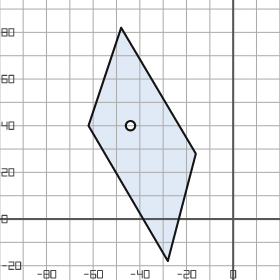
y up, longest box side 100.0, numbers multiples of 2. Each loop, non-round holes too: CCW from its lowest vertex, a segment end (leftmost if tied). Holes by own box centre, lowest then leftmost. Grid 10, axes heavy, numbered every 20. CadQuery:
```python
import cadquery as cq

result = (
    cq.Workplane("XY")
    .moveTo(-28.0, -18.0)
    .lineTo(-16.0, 28.0)
    .lineTo(-48.0, 82.0)
    .lineTo(-62.0, 40.0)
    .close()
    .moveTo(-44.0, 40.0)
    .circle(2.0)
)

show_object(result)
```